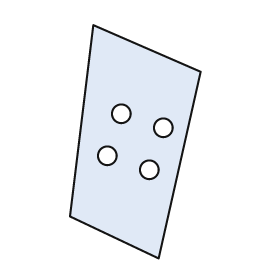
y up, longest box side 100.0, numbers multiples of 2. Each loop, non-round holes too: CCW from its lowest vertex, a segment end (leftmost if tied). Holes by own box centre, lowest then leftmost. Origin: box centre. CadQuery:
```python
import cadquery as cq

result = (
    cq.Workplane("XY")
    .moveTo(10.0, -50.0)
    .lineTo(28.0, 30.0)
    .lineTo(-18.0, 50.0)
    .lineTo(-28.0, -32.0)
    .close()
    .moveTo(6.0, -12.0)
    .circle(4.0)
    .moveTo(-12.0, -6.0)
    .circle(4.0)
    .moveTo(12.0, 6.0)
    .circle(4.0)
    .moveTo(-6.0, 12.0)
    .circle(4.0)
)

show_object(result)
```